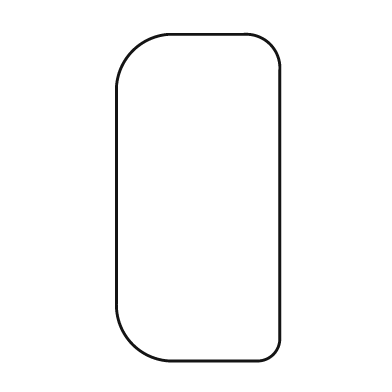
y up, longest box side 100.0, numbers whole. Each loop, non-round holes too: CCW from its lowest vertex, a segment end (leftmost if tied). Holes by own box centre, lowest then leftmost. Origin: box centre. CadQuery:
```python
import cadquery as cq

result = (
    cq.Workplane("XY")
    .moveTo(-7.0, -50.0)
    .lineTo(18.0, -50.0)
    .threePointArc((23.0, -48.0), (25.0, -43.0))
    .lineTo(25.0, 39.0)
    .threePointArc((22.0, 47.0), (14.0, 50.0))
    .lineTo(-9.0, 50.0)
    .threePointArc((-20.0, 45.0), (-25.0, 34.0))
    .lineTo(-25.0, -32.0)
    .threePointArc((-20.0, -45.0), (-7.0, -50.0))
    .close()
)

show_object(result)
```